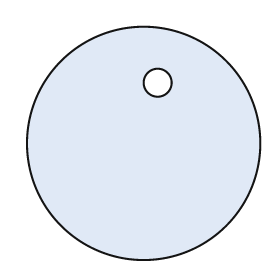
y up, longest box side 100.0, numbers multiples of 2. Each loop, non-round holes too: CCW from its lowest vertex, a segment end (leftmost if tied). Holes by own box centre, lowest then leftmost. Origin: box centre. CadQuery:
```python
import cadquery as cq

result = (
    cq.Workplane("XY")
    .moveTo(0.0, 0.0)
    .circle(50.0)
    .moveTo(6.0, 26.0)
    .circle(6.0)
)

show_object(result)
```